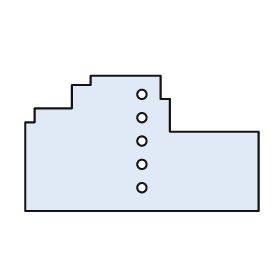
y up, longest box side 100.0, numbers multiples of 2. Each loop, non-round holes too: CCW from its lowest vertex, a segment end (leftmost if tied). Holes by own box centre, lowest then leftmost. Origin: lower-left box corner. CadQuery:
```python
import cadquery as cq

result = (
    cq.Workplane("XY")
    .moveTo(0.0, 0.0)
    .lineTo(100.0, 0.0)
    .lineTo(100.0, 34.0)
    .lineTo(62.0, 34.0)
    .lineTo(62.0, 48.0)
    .lineTo(58.0, 48.0)
    .lineTo(58.0, 58.0)
    .lineTo(28.0, 58.0)
    .lineTo(28.0, 54.0)
    .lineTo(20.0, 54.0)
    .lineTo(20.0, 44.0)
    .lineTo(4.0, 44.0)
    .lineTo(4.0, 38.0)
    .lineTo(0.0, 38.0)
    .close()
    .moveTo(50.0, 10.0)
    .circle(2.0)
    .moveTo(50.0, 20.0)
    .circle(2.0)
    .moveTo(50.0, 30.0)
    .circle(2.0)
    .moveTo(50.0, 40.0)
    .circle(2.0)
    .moveTo(50.0, 50.0)
    .circle(2.0)
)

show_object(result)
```